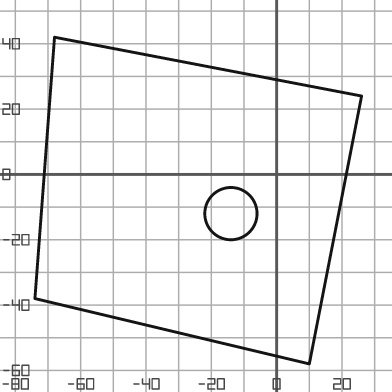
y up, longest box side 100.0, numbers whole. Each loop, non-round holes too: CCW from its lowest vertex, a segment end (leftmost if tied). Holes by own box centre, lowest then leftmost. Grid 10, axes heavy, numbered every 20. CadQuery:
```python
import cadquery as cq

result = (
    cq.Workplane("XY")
    .moveTo(10.0, -58.0)
    .lineTo(26.0, 24.0)
    .lineTo(-68.0, 42.0)
    .lineTo(-74.0, -38.0)
    .close()
    .moveTo(-14.0, -12.0)
    .circle(8.0)
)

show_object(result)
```